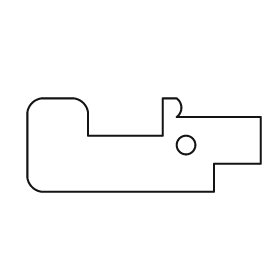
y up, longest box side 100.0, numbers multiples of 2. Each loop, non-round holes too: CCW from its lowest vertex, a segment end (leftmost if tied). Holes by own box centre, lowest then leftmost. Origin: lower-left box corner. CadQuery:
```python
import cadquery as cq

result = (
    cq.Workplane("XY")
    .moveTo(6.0, 0.0)
    .lineTo(80.0, 0.0)
    .lineTo(80.0, 12.0)
    .lineTo(100.0, 12.0)
    .lineTo(100.0, 32.0)
    .lineTo(64.0, 32.0)
    .threePointArc((66.0, 36.0), (64.0, 40.0))
    .lineTo(58.0, 40.0)
    .lineTo(58.0, 24.0)
    .lineTo(26.0, 24.0)
    .lineTo(26.0, 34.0)
    .threePointArc((24.0, 38.0), (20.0, 40.0))
    .lineTo(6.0, 40.0)
    .threePointArc((2.0, 38.0), (0.0, 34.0))
    .lineTo(0.0, 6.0)
    .threePointArc((2.0, 2.0), (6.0, 0.0))
    .close()
    .moveTo(68.0, 20.0)
    .circle(4.0)
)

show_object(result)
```